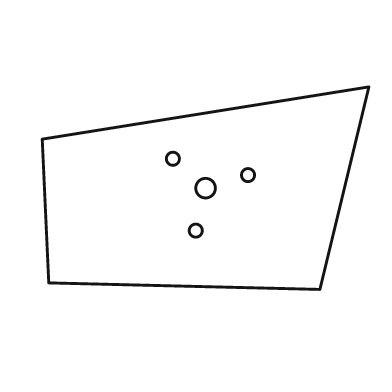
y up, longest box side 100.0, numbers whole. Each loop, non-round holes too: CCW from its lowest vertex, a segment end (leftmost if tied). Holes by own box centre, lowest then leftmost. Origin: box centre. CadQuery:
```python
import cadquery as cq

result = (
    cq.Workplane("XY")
    .moveTo(35.0, -31.0)
    .lineTo(50.0, 31.0)
    .lineTo(-50.0, 15.0)
    .lineTo(-48.0, -29.0)
    .close()
    .moveTo(-3.0, -13.0)
    .circle(2.0)
    .moveTo(0.0, 0.0)
    .circle(3.0)
    .moveTo(13.0, 4.0)
    .circle(2.0)
    .moveTo(-10.0, 9.0)
    .circle(2.0)
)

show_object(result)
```